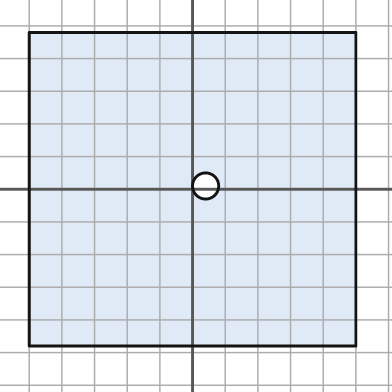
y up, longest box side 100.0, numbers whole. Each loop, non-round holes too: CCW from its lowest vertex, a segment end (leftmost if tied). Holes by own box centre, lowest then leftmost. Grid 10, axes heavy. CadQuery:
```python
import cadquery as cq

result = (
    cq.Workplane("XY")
    .moveTo(-50.0, -48.0)
    .lineTo(50.0, -48.0)
    .lineTo(50.0, 48.0)
    .lineTo(-50.0, 48.0)
    .close()
    .moveTo(4.0, 1.0)
    .circle(4.0)
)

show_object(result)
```